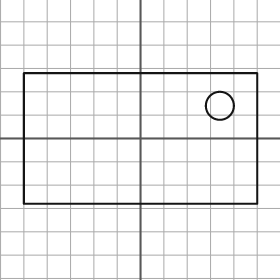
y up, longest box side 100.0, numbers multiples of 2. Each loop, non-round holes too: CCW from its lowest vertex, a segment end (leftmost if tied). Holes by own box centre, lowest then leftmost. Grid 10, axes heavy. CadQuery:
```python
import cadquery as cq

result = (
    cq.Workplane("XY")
    .moveTo(-50.0, -28.0)
    .lineTo(50.0, -28.0)
    .lineTo(50.0, 28.0)
    .lineTo(-50.0, 28.0)
    .close()
    .moveTo(34.0, 14.0)
    .circle(6.0)
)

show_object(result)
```